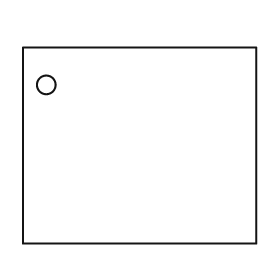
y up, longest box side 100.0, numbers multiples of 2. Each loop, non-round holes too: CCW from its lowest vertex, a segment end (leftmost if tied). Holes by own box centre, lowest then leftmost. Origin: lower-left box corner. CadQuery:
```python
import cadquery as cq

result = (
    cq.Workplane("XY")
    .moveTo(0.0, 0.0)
    .lineTo(100.0, 0.0)
    .lineTo(100.0, 84.0)
    .lineTo(0.0, 84.0)
    .close()
    .moveTo(10.0, 68.0)
    .circle(4.0)
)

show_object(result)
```